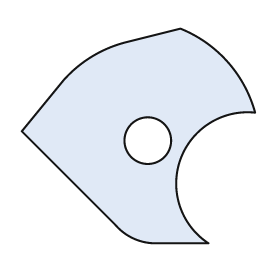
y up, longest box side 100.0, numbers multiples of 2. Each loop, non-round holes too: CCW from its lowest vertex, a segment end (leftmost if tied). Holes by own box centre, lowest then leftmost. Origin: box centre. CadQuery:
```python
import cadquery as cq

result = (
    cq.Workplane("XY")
    .moveTo(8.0, -46.0)
    .lineTo(30.0, -46.0)
    .threePointArc((18.0, -10.0), (50.0, 10.0))
    .threePointArc((38.0, 32.0), (18.0, 46.0))
    .lineTo(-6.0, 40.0)
    .threePointArc((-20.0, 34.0), (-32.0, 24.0))
    .lineTo(-50.0, 2.0)
    .lineTo(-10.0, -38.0)
    .threePointArc((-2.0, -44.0), (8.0, -46.0))
    .close()
    .moveTo(4.0, -2.0)
    .circle(10.0)
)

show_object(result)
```